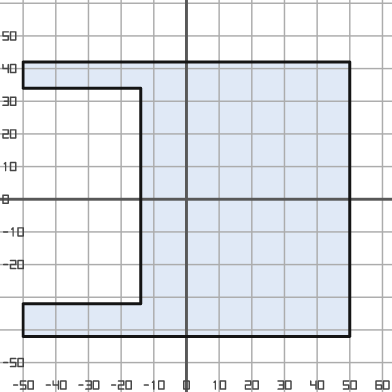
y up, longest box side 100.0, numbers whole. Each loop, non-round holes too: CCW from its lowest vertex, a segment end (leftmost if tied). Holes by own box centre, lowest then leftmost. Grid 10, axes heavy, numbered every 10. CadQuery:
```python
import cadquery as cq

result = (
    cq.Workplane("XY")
    .moveTo(-50.0, -42.0)
    .lineTo(50.0, -42.0)
    .lineTo(50.0, 42.0)
    .lineTo(-50.0, 42.0)
    .lineTo(-50.0, 34.0)
    .lineTo(-14.0, 34.0)
    .lineTo(-14.0, -32.0)
    .lineTo(-50.0, -32.0)
    .close()
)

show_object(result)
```